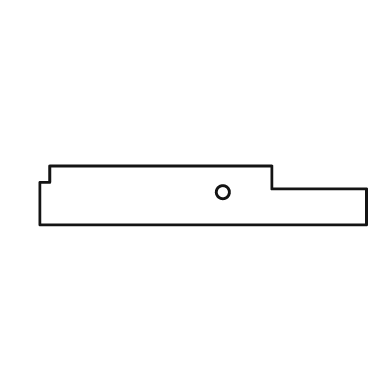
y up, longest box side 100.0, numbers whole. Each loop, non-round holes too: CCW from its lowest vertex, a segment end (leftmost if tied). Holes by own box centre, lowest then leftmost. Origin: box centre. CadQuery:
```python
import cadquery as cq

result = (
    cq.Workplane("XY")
    .moveTo(-50.0, -9.0)
    .lineTo(50.0, -9.0)
    .lineTo(50.0, 2.0)
    .lineTo(21.0, 2.0)
    .lineTo(21.0, 9.0)
    .lineTo(-47.0, 9.0)
    .lineTo(-47.0, 4.0)
    .lineTo(-50.0, 4.0)
    .close()
    .moveTo(6.0, 1.0)
    .circle(2.0)
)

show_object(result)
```